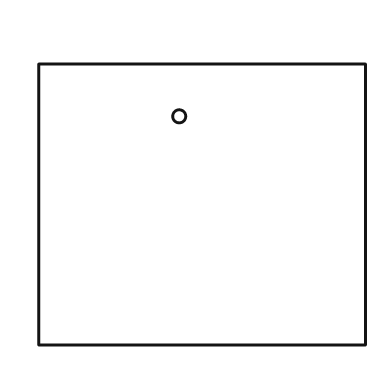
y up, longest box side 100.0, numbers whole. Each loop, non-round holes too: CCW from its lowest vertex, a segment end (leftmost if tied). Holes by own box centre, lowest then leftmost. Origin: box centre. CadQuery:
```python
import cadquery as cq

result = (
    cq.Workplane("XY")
    .moveTo(-50.0, -43.0)
    .lineTo(50.0, -43.0)
    .lineTo(50.0, 43.0)
    .lineTo(-50.0, 43.0)
    .close()
    .moveTo(-7.0, 27.0)
    .circle(2.0)
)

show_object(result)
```